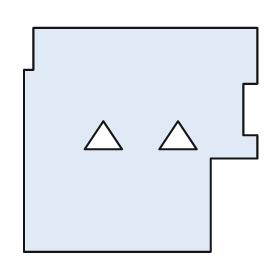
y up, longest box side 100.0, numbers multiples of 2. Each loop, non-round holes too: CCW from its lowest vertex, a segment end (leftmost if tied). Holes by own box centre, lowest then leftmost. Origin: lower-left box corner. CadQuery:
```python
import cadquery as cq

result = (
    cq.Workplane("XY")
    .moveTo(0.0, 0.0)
    .lineTo(80.0, 0.0)
    .lineTo(80.0, 40.0)
    .lineTo(100.0, 40.0)
    .lineTo(100.0, 50.0)
    .lineTo(94.0, 50.0)
    .lineTo(94.0, 72.0)
    .lineTo(100.0, 72.0)
    .lineTo(100.0, 96.0)
    .lineTo(4.0, 96.0)
    .lineTo(4.0, 78.0)
    .lineTo(0.0, 78.0)
    .close()
    .moveTo(26.0, 44.0)
    .lineTo(42.0, 44.0)
    .lineTo(34.0, 56.0)
    .close()
    .moveTo(58.0, 44.0)
    .lineTo(74.0, 44.0)
    .lineTo(66.0, 56.0)
    .close()
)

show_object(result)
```